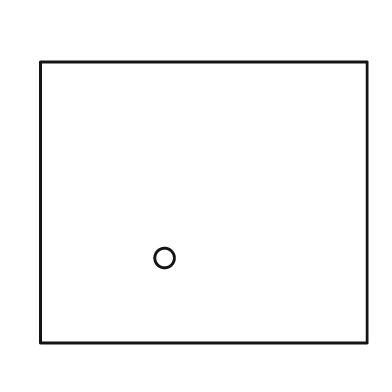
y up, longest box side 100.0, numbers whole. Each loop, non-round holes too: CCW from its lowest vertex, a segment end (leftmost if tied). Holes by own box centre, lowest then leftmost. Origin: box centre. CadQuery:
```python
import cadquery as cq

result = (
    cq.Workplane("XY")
    .moveTo(-50.0, -43.0)
    .lineTo(50.0, -43.0)
    .lineTo(50.0, 43.0)
    .lineTo(-50.0, 43.0)
    .close()
    .moveTo(-12.0, -17.0)
    .circle(3.0)
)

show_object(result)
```